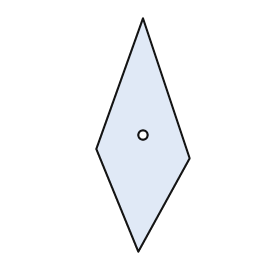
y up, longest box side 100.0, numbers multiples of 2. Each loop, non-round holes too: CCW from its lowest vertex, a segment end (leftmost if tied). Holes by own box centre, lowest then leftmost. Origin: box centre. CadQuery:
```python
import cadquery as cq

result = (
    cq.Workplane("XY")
    .moveTo(-2.0, -50.0)
    .lineTo(20.0, -10.0)
    .lineTo(0.0, 50.0)
    .lineTo(-20.0, -6.0)
    .close()
    .moveTo(0.0, 0.0)
    .circle(2.0)
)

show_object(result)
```